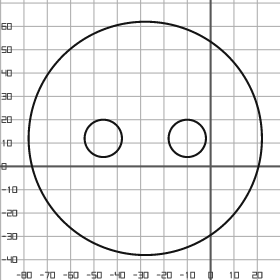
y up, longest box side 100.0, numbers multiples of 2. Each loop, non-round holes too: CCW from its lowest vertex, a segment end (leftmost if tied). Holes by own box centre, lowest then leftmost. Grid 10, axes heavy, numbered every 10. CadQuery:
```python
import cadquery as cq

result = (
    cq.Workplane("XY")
    .moveTo(-28.0, 12.0)
    .circle(50.0)
    .moveTo(-46.0, 12.0)
    .circle(8.0)
    .moveTo(-10.0, 12.0)
    .circle(8.0)
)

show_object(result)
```